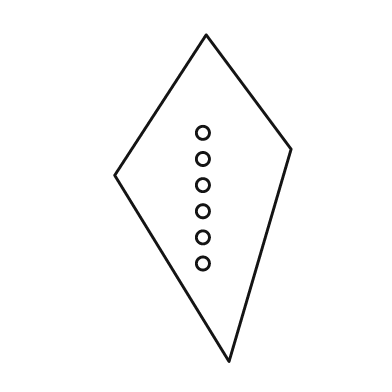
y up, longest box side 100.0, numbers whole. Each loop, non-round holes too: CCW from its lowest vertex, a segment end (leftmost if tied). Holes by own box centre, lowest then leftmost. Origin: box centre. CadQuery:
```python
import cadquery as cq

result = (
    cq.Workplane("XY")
    .moveTo(8.0, -50.0)
    .lineTo(27.0, 15.0)
    .lineTo(1.0, 50.0)
    .lineTo(-27.0, 7.0)
    .close()
    .moveTo(0.0, -20.0)
    .circle(2.0)
    .moveTo(0.0, -12.0)
    .circle(2.0)
    .moveTo(0.0, -4.0)
    .circle(2.0)
    .moveTo(0.0, 4.0)
    .circle(2.0)
    .moveTo(0.0, 12.0)
    .circle(2.0)
    .moveTo(0.0, 20.0)
    .circle(2.0)
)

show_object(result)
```